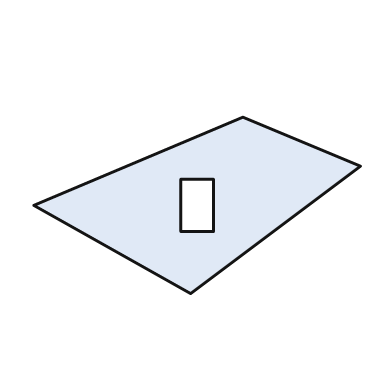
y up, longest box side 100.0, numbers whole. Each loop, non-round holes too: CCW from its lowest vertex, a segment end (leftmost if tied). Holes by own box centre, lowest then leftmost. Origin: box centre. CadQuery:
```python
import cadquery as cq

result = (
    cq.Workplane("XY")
    .moveTo(-2.0, -27.0)
    .lineTo(50.0, 12.0)
    .lineTo(14.0, 27.0)
    .lineTo(-50.0, 0.0)
    .close()
    .moveTo(-5.0, -8.0)
    .lineTo(5.0, -8.0)
    .lineTo(5.0, 8.0)
    .lineTo(-5.0, 8.0)
    .close()
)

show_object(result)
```